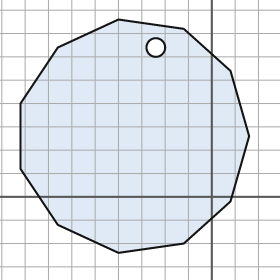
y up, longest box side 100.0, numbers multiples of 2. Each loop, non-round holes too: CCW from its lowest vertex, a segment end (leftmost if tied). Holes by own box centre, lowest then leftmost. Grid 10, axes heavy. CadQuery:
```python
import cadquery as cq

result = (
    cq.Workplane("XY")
    .moveTo(-40.0, -24.0)
    .lineTo(-12.0, -20.0)
    .lineTo(8.0, -2.0)
    .lineTo(16.0, 26.0)
    .lineTo(8.0, 54.0)
    .lineTo(-12.0, 72.0)
    .lineTo(-40.0, 76.0)
    .lineTo(-66.0, 64.0)
    .lineTo(-82.0, 40.0)
    .lineTo(-82.0, 12.0)
    .lineTo(-66.0, -12.0)
    .close()
    .moveTo(-24.0, 64.0)
    .circle(4.0)
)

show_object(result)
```